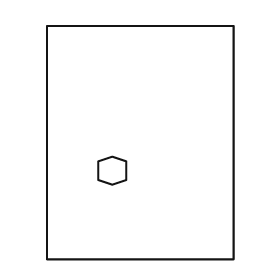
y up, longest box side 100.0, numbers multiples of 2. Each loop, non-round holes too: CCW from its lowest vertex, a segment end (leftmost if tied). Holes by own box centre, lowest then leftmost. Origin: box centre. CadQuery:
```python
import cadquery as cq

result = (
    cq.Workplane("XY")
    .moveTo(-40.0, -50.0)
    .lineTo(40.0, -50.0)
    .lineTo(40.0, 50.0)
    .lineTo(-40.0, 50.0)
    .close()
    .moveTo(-12.0, -18.0)
    .lineTo(-6.0, -16.0)
    .lineTo(-6.0, -8.0)
    .lineTo(-12.0, -6.0)
    .lineTo(-18.0, -8.0)
    .lineTo(-18.0, -16.0)
    .close()
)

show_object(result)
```